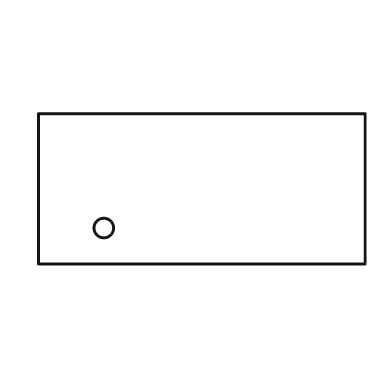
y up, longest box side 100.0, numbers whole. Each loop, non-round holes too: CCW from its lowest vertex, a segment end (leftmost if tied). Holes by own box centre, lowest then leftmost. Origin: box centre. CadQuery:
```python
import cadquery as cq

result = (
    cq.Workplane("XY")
    .moveTo(-50.0, -23.0)
    .lineTo(50.0, -23.0)
    .lineTo(50.0, 23.0)
    .lineTo(-50.0, 23.0)
    .close()
    .moveTo(-30.0, -12.0)
    .circle(3.0)
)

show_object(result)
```